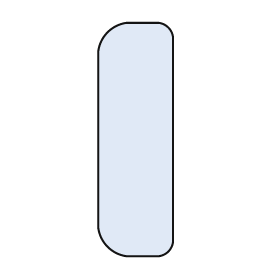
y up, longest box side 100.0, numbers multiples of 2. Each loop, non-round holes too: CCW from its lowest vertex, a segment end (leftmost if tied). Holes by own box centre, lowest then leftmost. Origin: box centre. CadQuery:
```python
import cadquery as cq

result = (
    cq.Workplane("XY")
    .moveTo(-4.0, -50.0)
    .lineTo(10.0, -50.0)
    .threePointArc((14.0, -48.0), (16.0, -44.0))
    .lineTo(16.0, 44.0)
    .threePointArc((14.0, 48.0), (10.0, 50.0))
    .lineTo(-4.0, 50.0)
    .threePointArc((-12.0, 46.0), (-16.0, 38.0))
    .lineTo(-16.0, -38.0)
    .threePointArc((-12.0, -46.0), (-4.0, -50.0))
    .close()
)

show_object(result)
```